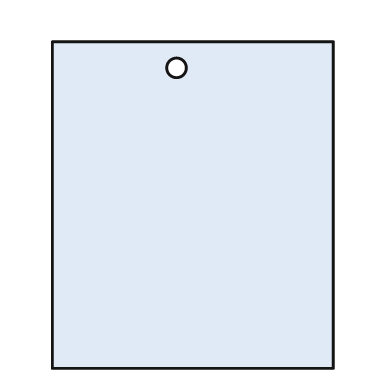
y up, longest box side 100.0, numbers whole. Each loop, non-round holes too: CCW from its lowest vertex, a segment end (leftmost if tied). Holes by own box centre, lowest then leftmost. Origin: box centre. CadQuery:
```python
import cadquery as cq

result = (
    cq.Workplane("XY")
    .moveTo(-43.0, -50.0)
    .lineTo(43.0, -50.0)
    .lineTo(43.0, 50.0)
    .lineTo(-43.0, 50.0)
    .close()
    .moveTo(-5.0, 42.0)
    .circle(3.0)
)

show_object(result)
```